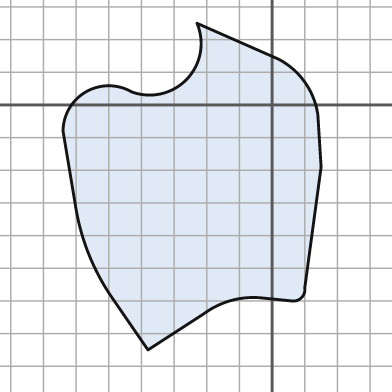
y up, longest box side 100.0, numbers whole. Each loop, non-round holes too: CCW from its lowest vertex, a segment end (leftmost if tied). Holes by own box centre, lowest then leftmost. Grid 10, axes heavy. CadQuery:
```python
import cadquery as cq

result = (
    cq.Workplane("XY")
    .moveTo(-38.0, -75.0)
    .lineTo(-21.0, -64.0)
    .threePointArc((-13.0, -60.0), (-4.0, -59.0))
    .lineTo(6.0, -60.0)
    .threePointArc((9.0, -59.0), (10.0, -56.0))
    .lineTo(15.0, -19.0)
    .lineTo(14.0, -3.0)
    .threePointArc((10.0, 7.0), (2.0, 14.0))
    .lineTo(-23.0, 25.0)
    .threePointArc((-26.0, 8.0), (-43.0, 4.0))
    .threePointArc((-57.0, 4.0), (-64.0, -8.0))
    .lineTo(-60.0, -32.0)
    .threePointArc((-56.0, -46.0), (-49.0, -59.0))
    .close()
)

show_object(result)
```